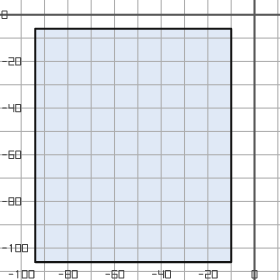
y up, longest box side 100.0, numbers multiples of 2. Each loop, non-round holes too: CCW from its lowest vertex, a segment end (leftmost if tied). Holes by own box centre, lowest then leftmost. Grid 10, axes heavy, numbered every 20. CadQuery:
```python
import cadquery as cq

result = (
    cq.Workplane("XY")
    .moveTo(-94.0, -106.0)
    .lineTo(-10.0, -106.0)
    .lineTo(-10.0, -6.0)
    .lineTo(-94.0, -6.0)
    .close()
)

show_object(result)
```